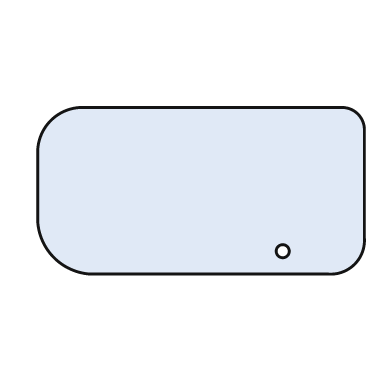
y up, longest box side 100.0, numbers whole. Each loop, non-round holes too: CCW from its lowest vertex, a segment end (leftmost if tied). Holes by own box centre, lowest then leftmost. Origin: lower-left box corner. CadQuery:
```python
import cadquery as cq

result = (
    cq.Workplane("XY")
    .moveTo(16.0, 0.0)
    .lineTo(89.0, 0.0)
    .threePointArc((97.0, 3.0), (100.0, 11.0))
    .lineTo(100.0, 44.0)
    .threePointArc((98.0, 49.0), (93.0, 51.0))
    .lineTo(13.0, 51.0)
    .threePointArc((4.0, 47.0), (0.0, 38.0))
    .lineTo(0.0, 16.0)
    .threePointArc((5.0, 5.0), (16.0, 0.0))
    .close()
    .moveTo(75.0, 7.0)
    .circle(2.0)
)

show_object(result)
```